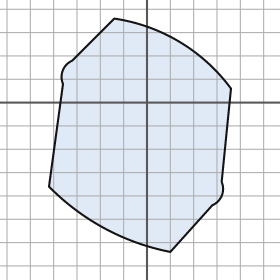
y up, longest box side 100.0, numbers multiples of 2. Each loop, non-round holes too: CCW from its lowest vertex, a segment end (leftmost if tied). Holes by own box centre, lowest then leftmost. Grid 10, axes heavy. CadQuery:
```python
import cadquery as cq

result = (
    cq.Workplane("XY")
    .moveTo(10.0, -64.0)
    .lineTo(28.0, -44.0)
    .threePointArc((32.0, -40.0), (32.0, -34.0))
    .lineTo(36.0, 6.0)
    .threePointArc((14.0, 26.0), (-14.0, 36.0))
    .lineTo(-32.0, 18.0)
    .threePointArc((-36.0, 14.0), (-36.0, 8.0))
    .lineTo(-42.0, -36.0)
    .threePointArc((-18.0, -54.0), (10.0, -64.0))
    .close()
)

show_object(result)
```